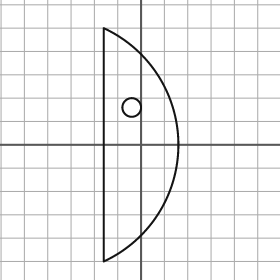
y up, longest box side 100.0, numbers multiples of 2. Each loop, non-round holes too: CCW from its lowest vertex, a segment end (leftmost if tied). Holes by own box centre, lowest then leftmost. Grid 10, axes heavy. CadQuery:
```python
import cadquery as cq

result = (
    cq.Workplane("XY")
    .moveTo(-16.0, -50.0)
    .threePointArc((16.0, 0.0), (-16.0, 50.0))
    .close()
    .moveTo(-4.0, 16.0)
    .circle(4.0)
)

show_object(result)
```